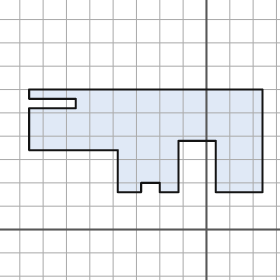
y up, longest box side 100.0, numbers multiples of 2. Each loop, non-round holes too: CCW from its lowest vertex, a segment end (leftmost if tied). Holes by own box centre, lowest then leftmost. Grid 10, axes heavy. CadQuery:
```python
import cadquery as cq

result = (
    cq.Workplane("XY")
    .moveTo(-38.0, 16.0)
    .lineTo(-28.0, 16.0)
    .lineTo(-28.0, 20.0)
    .lineTo(-20.0, 20.0)
    .lineTo(-20.0, 16.0)
    .lineTo(-12.0, 16.0)
    .lineTo(-12.0, 38.0)
    .lineTo(4.0, 38.0)
    .lineTo(4.0, 16.0)
    .lineTo(24.0, 16.0)
    .lineTo(24.0, 60.0)
    .lineTo(-76.0, 60.0)
    .lineTo(-76.0, 56.0)
    .lineTo(-56.0, 56.0)
    .lineTo(-56.0, 52.0)
    .lineTo(-76.0, 52.0)
    .lineTo(-76.0, 34.0)
    .lineTo(-38.0, 34.0)
    .close()
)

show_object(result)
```